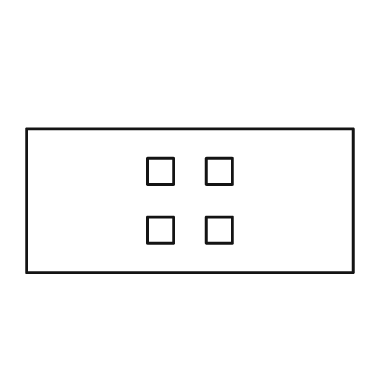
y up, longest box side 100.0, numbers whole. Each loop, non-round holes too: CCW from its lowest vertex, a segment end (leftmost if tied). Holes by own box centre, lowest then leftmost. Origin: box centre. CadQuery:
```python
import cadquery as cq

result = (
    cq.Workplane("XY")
    .moveTo(-50.0, -22.0)
    .lineTo(50.0, -22.0)
    .lineTo(50.0, 22.0)
    .lineTo(-50.0, 22.0)
    .close()
    .moveTo(-13.0, -13.0)
    .lineTo(-5.0, -13.0)
    .lineTo(-5.0, -5.0)
    .lineTo(-13.0, -5.0)
    .close()
    .moveTo(5.0, -13.0)
    .lineTo(13.0, -13.0)
    .lineTo(13.0, -5.0)
    .lineTo(5.0, -5.0)
    .close()
    .moveTo(-13.0, 5.0)
    .lineTo(-5.0, 5.0)
    .lineTo(-5.0, 13.0)
    .lineTo(-13.0, 13.0)
    .close()
    .moveTo(5.0, 5.0)
    .lineTo(13.0, 5.0)
    .lineTo(13.0, 13.0)
    .lineTo(5.0, 13.0)
    .close()
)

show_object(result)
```